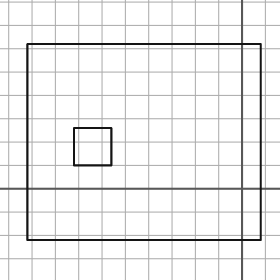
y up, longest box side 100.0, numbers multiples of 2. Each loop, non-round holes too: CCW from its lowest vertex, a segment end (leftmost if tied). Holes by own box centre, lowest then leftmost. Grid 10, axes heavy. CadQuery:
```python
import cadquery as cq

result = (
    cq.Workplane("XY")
    .moveTo(-92.0, -22.0)
    .lineTo(8.0, -22.0)
    .lineTo(8.0, 62.0)
    .lineTo(-92.0, 62.0)
    .close()
    .moveTo(-72.0, 10.0)
    .lineTo(-56.0, 10.0)
    .lineTo(-56.0, 26.0)
    .lineTo(-72.0, 26.0)
    .close()
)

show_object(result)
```